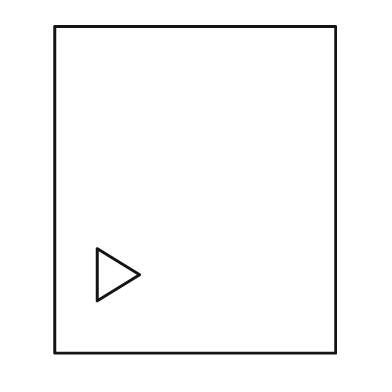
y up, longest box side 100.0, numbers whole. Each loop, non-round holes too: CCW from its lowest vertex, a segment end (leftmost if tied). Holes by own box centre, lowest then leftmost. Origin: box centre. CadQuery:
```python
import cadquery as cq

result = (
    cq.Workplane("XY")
    .moveTo(-43.0, -50.0)
    .lineTo(43.0, -50.0)
    .lineTo(43.0, 50.0)
    .lineTo(-43.0, 50.0)
    .close()
    .moveTo(-30.0, -34.0)
    .lineTo(-17.0, -26.0)
    .lineTo(-30.0, -18.0)
    .close()
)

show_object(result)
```